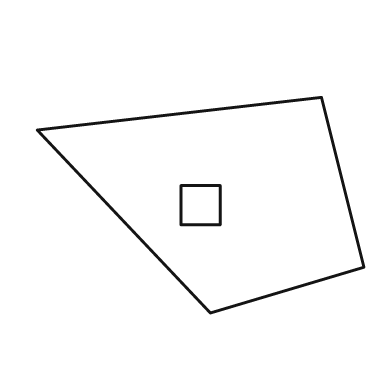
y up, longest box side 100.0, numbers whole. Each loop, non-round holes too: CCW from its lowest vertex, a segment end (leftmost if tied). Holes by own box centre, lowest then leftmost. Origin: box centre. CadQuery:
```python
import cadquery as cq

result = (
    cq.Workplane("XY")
    .moveTo(3.0, -33.0)
    .lineTo(50.0, -19.0)
    .lineTo(37.0, 33.0)
    .lineTo(-50.0, 23.0)
    .close()
    .moveTo(-6.0, -6.0)
    .lineTo(6.0, -6.0)
    .lineTo(6.0, 6.0)
    .lineTo(-6.0, 6.0)
    .close()
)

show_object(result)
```